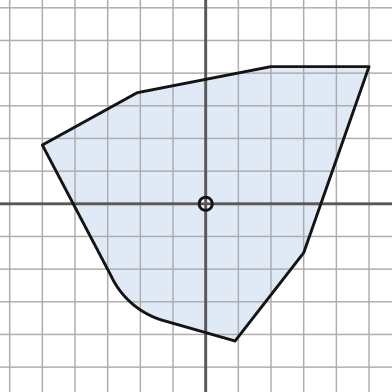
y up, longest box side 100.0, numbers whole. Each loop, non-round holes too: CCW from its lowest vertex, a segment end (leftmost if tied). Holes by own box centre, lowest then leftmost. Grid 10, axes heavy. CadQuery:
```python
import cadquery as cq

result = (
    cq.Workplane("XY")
    .moveTo(9.0, -42.0)
    .lineTo(30.0, -15.0)
    .lineTo(50.0, 42.0)
    .lineTo(20.0, 42.0)
    .lineTo(-21.0, 34.0)
    .lineTo(-50.0, 18.0)
    .lineTo(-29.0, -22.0)
    .threePointArc((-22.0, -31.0), (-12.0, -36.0))
    .close()
    .moveTo(0.0, 0.0)
    .circle(2.0)
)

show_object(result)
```